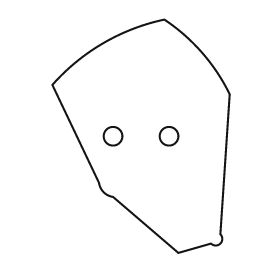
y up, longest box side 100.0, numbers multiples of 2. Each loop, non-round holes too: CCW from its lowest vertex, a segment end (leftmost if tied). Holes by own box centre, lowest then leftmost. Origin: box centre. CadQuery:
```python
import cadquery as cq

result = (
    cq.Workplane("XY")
    .moveTo(16.0, -50.0)
    .lineTo(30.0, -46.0)
    .threePointArc((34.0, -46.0), (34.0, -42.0))
    .lineTo(38.0, 18.0)
    .threePointArc((26.0, 36.0), (10.0, 50.0))
    .threePointArc((-16.0, 40.0), (-38.0, 22.0))
    .lineTo(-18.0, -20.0)
    .threePointArc((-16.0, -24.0), (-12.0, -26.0))
    .close()
    .moveTo(-12.0, 0.0)
    .circle(4.0)
    .moveTo(12.0, 0.0)
    .circle(4.0)
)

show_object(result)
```